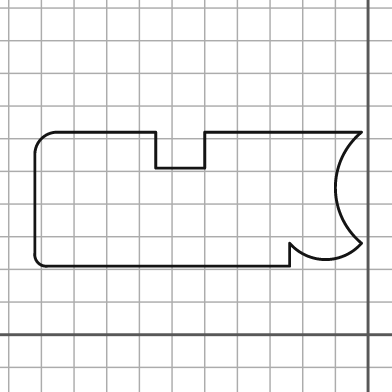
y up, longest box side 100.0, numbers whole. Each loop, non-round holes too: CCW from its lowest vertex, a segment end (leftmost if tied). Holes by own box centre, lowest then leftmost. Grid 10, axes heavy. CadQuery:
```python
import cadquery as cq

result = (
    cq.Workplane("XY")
    .moveTo(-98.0, 21.0)
    .lineTo(-24.0, 21.0)
    .lineTo(-24.0, 28.0)
    .threePointArc((-13.0, 23.0), (-2.0, 28.0))
    .threePointArc((-10.0, 45.0), (-2.0, 62.0))
    .lineTo(-50.0, 62.0)
    .lineTo(-50.0, 51.0)
    .lineTo(-65.0, 51.0)
    .lineTo(-65.0, 62.0)
    .lineTo(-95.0, 62.0)
    .threePointArc((-100.0, 60.0), (-102.0, 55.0))
    .lineTo(-102.0, 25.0)
    .threePointArc((-101.0, 22.0), (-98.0, 21.0))
    .close()
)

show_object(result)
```